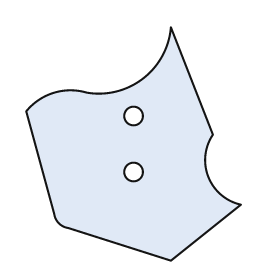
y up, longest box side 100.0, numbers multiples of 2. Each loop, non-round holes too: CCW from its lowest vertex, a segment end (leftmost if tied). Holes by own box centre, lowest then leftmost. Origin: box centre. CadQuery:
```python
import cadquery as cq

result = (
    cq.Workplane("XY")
    .moveTo(16.0, -50.0)
    .lineTo(46.0, -26.0)
    .threePointArc((32.0, -14.0), (34.0, 4.0))
    .lineTo(16.0, 50.0)
    .threePointArc((4.0, 28.0), (-20.0, 22.0))
    .threePointArc((-34.0, 22.0), (-46.0, 14.0))
    .lineTo(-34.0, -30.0)
    .threePointArc((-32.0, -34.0), (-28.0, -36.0))
    .close()
    .moveTo(0.0, -12.0)
    .circle(4.0)
    .moveTo(0.0, 12.0)
    .circle(4.0)
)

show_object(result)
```